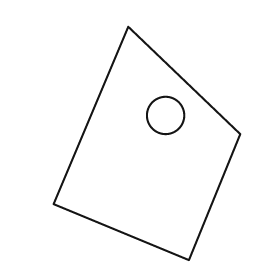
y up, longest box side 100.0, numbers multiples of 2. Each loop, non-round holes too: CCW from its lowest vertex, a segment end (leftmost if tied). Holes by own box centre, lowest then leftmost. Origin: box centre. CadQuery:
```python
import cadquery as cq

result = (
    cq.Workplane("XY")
    .moveTo(18.0, -50.0)
    .lineTo(40.0, 4.0)
    .lineTo(-8.0, 50.0)
    .lineTo(-40.0, -26.0)
    .close()
    .moveTo(8.0, 12.0)
    .circle(8.0)
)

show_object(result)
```